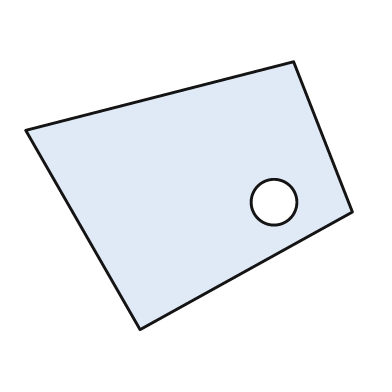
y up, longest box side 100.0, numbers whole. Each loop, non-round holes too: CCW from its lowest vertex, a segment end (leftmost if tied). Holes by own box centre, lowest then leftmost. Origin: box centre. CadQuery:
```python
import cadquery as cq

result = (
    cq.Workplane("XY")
    .moveTo(-15.0, -41.0)
    .lineTo(50.0, -5.0)
    .lineTo(32.0, 41.0)
    .lineTo(-50.0, 20.0)
    .close()
    .moveTo(26.0, -2.0)
    .circle(7.0)
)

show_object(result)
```